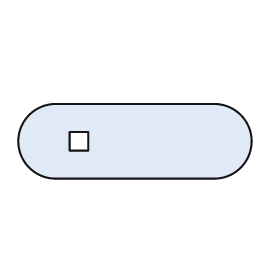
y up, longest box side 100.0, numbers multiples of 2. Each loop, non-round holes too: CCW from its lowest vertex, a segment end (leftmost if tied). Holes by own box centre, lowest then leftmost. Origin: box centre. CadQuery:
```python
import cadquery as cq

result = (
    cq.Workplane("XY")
    .moveTo(-34.0, -16.0)
    .lineTo(34.0, -16.0)
    .threePointArc((50.0, 0.0), (34.0, 16.0))
    .lineTo(-34.0, 16.0)
    .threePointArc((-50.0, 0.0), (-34.0, -16.0))
    .close()
    .moveTo(-28.0, -4.0)
    .lineTo(-20.0, -4.0)
    .lineTo(-20.0, 4.0)
    .lineTo(-28.0, 4.0)
    .close()
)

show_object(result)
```